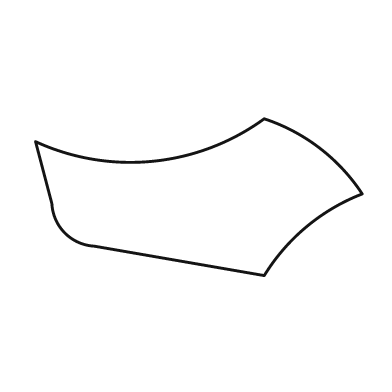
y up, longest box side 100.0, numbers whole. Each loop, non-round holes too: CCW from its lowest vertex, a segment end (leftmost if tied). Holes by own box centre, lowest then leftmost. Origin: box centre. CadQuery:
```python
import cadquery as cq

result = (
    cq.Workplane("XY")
    .moveTo(20.0, -24.0)
    .threePointArc((33.0, -9.0), (50.0, 1.0))
    .threePointArc((37.0, 15.0), (20.0, 24.0))
    .threePointArc((-14.0, 11.0), (-50.0, 17.0))
    .lineTo(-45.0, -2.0)
    .threePointArc((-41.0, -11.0), (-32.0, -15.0))
    .close()
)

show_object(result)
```